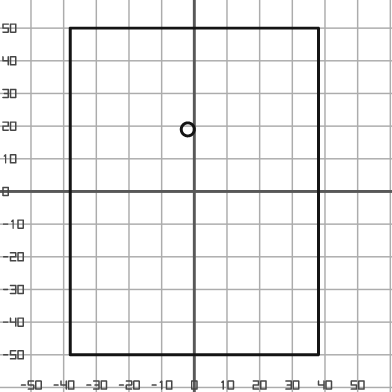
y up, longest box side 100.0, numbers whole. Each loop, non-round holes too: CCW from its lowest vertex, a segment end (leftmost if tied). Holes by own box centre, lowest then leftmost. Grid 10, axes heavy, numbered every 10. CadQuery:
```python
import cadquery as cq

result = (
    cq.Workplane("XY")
    .moveTo(-38.0, -50.0)
    .lineTo(38.0, -50.0)
    .lineTo(38.0, 50.0)
    .lineTo(-38.0, 50.0)
    .close()
    .moveTo(-2.0, 19.0)
    .circle(2.0)
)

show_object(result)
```